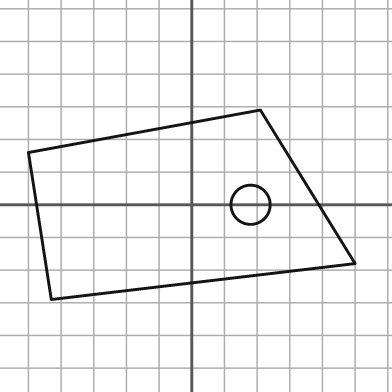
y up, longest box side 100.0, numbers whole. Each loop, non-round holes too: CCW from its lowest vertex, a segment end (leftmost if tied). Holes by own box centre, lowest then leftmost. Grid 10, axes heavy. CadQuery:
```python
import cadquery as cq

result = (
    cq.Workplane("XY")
    .moveTo(-43.0, -29.0)
    .lineTo(50.0, -18.0)
    .lineTo(21.0, 29.0)
    .lineTo(-50.0, 16.0)
    .close()
    .moveTo(18.0, 0.0)
    .circle(6.0)
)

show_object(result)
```